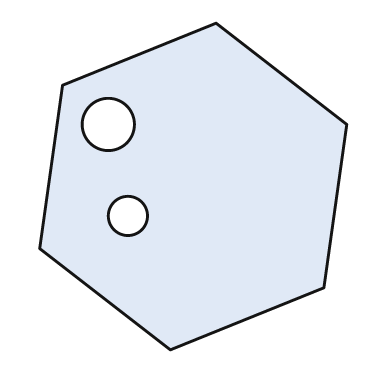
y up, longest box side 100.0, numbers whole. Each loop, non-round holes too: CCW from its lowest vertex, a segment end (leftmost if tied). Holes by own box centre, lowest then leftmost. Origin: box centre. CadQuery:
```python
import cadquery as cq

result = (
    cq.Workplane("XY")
    .moveTo(-7.0, -50.0)
    .lineTo(40.0, -31.0)
    .lineTo(47.0, 19.0)
    .lineTo(7.0, 50.0)
    .lineTo(-40.0, 31.0)
    .lineTo(-47.0, -19.0)
    .close()
    .moveTo(-20.0, -9.0)
    .circle(6.0)
    .moveTo(-26.0, 19.0)
    .circle(8.0)
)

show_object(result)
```